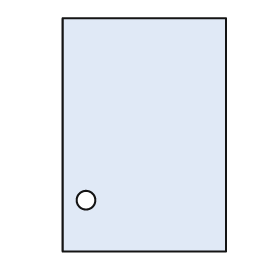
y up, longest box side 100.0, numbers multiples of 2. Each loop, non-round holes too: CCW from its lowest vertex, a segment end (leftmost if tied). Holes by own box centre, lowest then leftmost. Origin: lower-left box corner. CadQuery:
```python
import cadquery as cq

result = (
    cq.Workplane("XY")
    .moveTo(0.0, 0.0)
    .lineTo(70.0, 0.0)
    .lineTo(70.0, 100.0)
    .lineTo(0.0, 100.0)
    .close()
    .moveTo(10.0, 22.0)
    .circle(4.0)
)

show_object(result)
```